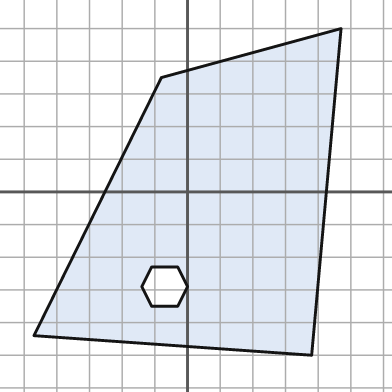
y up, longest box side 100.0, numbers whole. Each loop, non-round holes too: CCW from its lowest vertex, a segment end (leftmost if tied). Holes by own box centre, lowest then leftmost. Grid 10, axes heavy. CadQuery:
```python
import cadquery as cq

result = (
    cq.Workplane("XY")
    .moveTo(38.0, -50.0)
    .lineTo(47.0, 50.0)
    .lineTo(-8.0, 35.0)
    .lineTo(-47.0, -44.0)
    .close()
    .moveTo(-11.0, -35.0)
    .lineTo(-3.0, -35.0)
    .lineTo(0.0, -29.0)
    .lineTo(-3.0, -23.0)
    .lineTo(-11.0, -23.0)
    .lineTo(-14.0, -29.0)
    .close()
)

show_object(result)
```